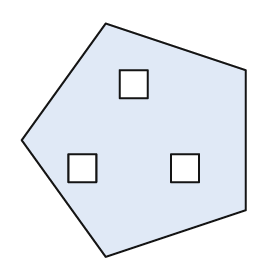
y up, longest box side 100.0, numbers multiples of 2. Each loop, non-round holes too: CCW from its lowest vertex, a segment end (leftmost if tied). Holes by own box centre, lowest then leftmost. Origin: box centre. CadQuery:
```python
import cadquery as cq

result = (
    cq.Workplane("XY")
    .moveTo(-12.0, -50.0)
    .lineTo(48.0, -30.0)
    .lineTo(48.0, 30.0)
    .lineTo(-12.0, 50.0)
    .lineTo(-48.0, 0.0)
    .close()
    .moveTo(-28.0, -18.0)
    .lineTo(-16.0, -18.0)
    .lineTo(-16.0, -6.0)
    .lineTo(-28.0, -6.0)
    .close()
    .moveTo(16.0, -18.0)
    .lineTo(28.0, -18.0)
    .lineTo(28.0, -6.0)
    .lineTo(16.0, -6.0)
    .close()
    .moveTo(-6.0, 18.0)
    .lineTo(6.0, 18.0)
    .lineTo(6.0, 30.0)
    .lineTo(-6.0, 30.0)
    .close()
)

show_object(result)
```